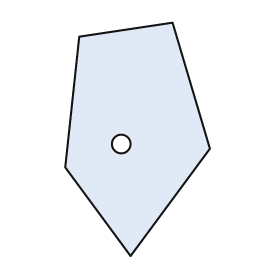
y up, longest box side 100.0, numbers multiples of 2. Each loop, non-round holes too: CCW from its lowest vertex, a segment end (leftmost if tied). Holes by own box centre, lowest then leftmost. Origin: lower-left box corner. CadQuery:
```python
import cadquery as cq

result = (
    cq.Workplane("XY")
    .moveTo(28.0, 0.0)
    .lineTo(62.0, 46.0)
    .lineTo(46.0, 100.0)
    .lineTo(6.0, 94.0)
    .lineTo(0.0, 38.0)
    .close()
    .moveTo(24.0, 48.0)
    .circle(4.0)
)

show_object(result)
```